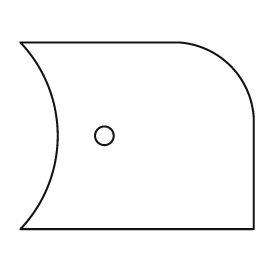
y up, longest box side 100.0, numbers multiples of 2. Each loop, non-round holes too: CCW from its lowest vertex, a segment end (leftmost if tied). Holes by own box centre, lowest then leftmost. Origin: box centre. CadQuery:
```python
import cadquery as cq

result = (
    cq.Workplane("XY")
    .moveTo(-50.0, -40.0)
    .lineTo(50.0, -40.0)
    .lineTo(50.0, 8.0)
    .threePointArc((40.0, 30.0), (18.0, 40.0))
    .lineTo(-50.0, 40.0)
    .threePointArc((-34.0, 0.0), (-50.0, -40.0))
    .close()
    .moveTo(-14.0, 0.0)
    .circle(4.0)
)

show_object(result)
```